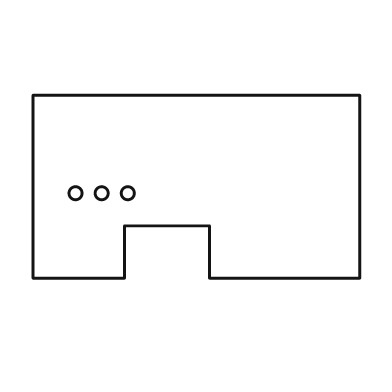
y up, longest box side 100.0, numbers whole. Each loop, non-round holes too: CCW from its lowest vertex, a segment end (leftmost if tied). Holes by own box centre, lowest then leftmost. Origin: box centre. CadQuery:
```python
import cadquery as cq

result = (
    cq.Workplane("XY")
    .moveTo(-50.0, -28.0)
    .lineTo(-22.0, -28.0)
    .lineTo(-22.0, -12.0)
    .lineTo(4.0, -12.0)
    .lineTo(4.0, -28.0)
    .lineTo(50.0, -28.0)
    .lineTo(50.0, 28.0)
    .lineTo(-50.0, 28.0)
    .close()
    .moveTo(-37.0, -2.0)
    .circle(2.0)
    .moveTo(-29.0, -2.0)
    .circle(2.0)
    .moveTo(-21.0, -2.0)
    .circle(2.0)
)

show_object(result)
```